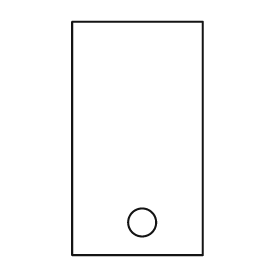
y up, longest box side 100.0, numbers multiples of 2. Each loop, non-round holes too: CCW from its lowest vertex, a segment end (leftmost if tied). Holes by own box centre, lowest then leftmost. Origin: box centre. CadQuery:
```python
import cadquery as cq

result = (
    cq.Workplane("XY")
    .moveTo(-28.0, -50.0)
    .lineTo(28.0, -50.0)
    .lineTo(28.0, 50.0)
    .lineTo(-28.0, 50.0)
    .close()
    .moveTo(2.0, -36.0)
    .circle(6.0)
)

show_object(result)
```